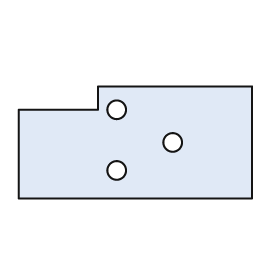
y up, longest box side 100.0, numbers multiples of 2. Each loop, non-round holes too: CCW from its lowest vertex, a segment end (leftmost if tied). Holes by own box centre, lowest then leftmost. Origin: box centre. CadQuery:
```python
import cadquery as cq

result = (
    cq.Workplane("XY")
    .moveTo(-50.0, -24.0)
    .lineTo(50.0, -24.0)
    .lineTo(50.0, 24.0)
    .lineTo(-16.0, 24.0)
    .lineTo(-16.0, 14.0)
    .lineTo(-50.0, 14.0)
    .close()
    .moveTo(-8.0, -12.0)
    .circle(4.0)
    .moveTo(16.0, 0.0)
    .circle(4.0)
    .moveTo(-8.0, 14.0)
    .circle(4.0)
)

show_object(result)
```